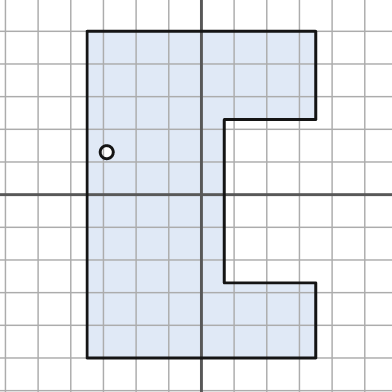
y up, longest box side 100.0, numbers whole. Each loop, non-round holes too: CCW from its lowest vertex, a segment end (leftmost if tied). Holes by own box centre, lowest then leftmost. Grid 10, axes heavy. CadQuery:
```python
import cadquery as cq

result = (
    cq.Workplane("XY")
    .moveTo(-35.0, -50.0)
    .lineTo(35.0, -50.0)
    .lineTo(35.0, -27.0)
    .lineTo(7.0, -27.0)
    .lineTo(7.0, 23.0)
    .lineTo(35.0, 23.0)
    .lineTo(35.0, 50.0)
    .lineTo(-35.0, 50.0)
    .close()
    .moveTo(-29.0, 13.0)
    .circle(2.0)
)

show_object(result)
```